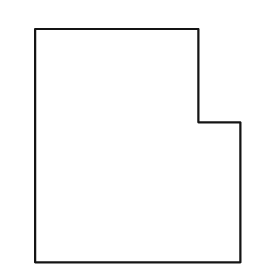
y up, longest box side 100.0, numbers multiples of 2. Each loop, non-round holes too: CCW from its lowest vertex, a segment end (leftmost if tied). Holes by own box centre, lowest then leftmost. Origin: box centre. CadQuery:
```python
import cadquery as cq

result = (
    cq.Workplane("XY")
    .moveTo(-44.0, -50.0)
    .lineTo(44.0, -50.0)
    .lineTo(44.0, 10.0)
    .lineTo(26.0, 10.0)
    .lineTo(26.0, 50.0)
    .lineTo(-44.0, 50.0)
    .close()
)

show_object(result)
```